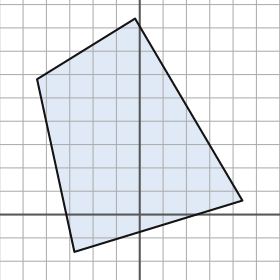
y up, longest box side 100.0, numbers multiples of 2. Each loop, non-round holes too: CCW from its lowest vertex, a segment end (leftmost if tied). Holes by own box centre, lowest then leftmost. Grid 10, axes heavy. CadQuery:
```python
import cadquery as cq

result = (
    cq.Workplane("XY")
    .moveTo(-28.0, -16.0)
    .lineTo(44.0, 6.0)
    .lineTo(-2.0, 84.0)
    .lineTo(-44.0, 58.0)
    .close()
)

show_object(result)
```